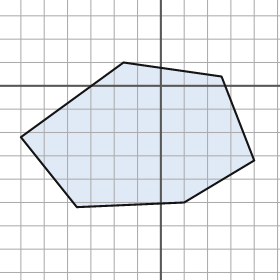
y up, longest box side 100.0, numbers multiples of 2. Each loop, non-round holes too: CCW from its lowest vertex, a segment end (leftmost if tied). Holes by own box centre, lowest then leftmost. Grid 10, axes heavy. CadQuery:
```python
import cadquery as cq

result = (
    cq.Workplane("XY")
    .moveTo(-36.0, -52.0)
    .lineTo(10.0, -50.0)
    .lineTo(40.0, -32.0)
    .lineTo(26.0, 4.0)
    .lineTo(-16.0, 10.0)
    .lineTo(-60.0, -22.0)
    .close()
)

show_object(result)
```